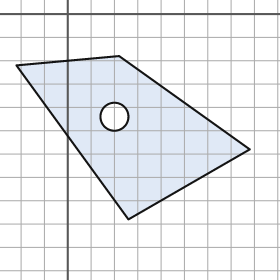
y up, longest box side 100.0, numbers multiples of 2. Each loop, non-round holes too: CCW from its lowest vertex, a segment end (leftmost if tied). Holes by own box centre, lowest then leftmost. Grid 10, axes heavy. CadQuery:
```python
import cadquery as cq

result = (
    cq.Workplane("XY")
    .moveTo(26.0, -88.0)
    .lineTo(78.0, -58.0)
    .lineTo(22.0, -18.0)
    .lineTo(-22.0, -22.0)
    .close()
    .moveTo(20.0, -44.0)
    .circle(6.0)
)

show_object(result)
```